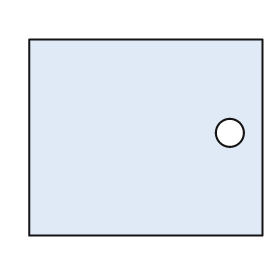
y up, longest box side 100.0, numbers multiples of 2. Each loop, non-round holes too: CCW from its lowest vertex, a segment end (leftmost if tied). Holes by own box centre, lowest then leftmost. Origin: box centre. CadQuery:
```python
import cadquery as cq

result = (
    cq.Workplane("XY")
    .moveTo(-50.0, -42.0)
    .lineTo(50.0, -42.0)
    .lineTo(50.0, 42.0)
    .lineTo(-50.0, 42.0)
    .close()
    .moveTo(36.0, 2.0)
    .circle(6.0)
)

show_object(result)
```